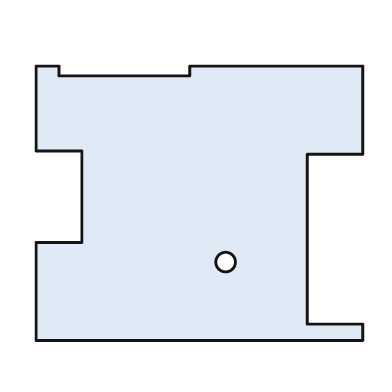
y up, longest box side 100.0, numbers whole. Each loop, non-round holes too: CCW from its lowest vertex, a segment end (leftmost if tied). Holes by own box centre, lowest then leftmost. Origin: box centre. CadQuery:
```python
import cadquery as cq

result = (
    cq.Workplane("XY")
    .moveTo(-50.0, -42.0)
    .lineTo(50.0, -42.0)
    .lineTo(50.0, -37.0)
    .lineTo(33.0, -37.0)
    .lineTo(33.0, 15.0)
    .lineTo(50.0, 15.0)
    .lineTo(50.0, 42.0)
    .lineTo(-3.0, 42.0)
    .lineTo(-3.0, 39.0)
    .lineTo(-43.0, 39.0)
    .lineTo(-43.0, 42.0)
    .lineTo(-50.0, 42.0)
    .lineTo(-50.0, 16.0)
    .lineTo(-36.0, 16.0)
    .lineTo(-36.0, -12.0)
    .lineTo(-50.0, -12.0)
    .close()
    .moveTo(8.0, -18.0)
    .circle(3.0)
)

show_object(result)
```